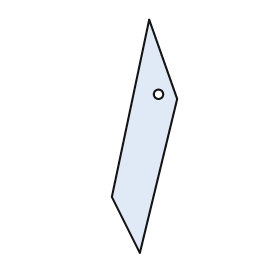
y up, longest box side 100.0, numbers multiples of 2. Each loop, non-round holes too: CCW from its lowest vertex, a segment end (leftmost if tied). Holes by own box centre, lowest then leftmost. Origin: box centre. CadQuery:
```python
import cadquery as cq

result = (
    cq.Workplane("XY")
    .moveTo(-2.0, -50.0)
    .lineTo(14.0, 16.0)
    .lineTo(2.0, 50.0)
    .lineTo(-14.0, -26.0)
    .close()
    .moveTo(6.0, 18.0)
    .circle(2.0)
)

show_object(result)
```